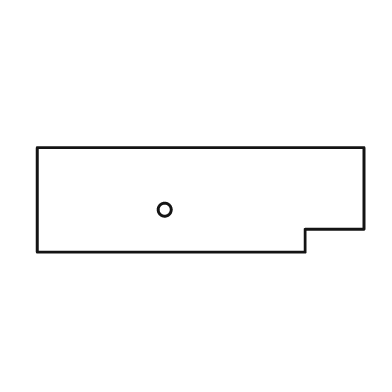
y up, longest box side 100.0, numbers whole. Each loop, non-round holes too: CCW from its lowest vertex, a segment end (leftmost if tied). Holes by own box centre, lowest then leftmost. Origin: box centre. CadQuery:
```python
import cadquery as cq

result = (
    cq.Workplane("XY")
    .moveTo(-50.0, -16.0)
    .lineTo(32.0, -16.0)
    .lineTo(32.0, -9.0)
    .lineTo(50.0, -9.0)
    .lineTo(50.0, 16.0)
    .lineTo(-50.0, 16.0)
    .close()
    .moveTo(-11.0, -3.0)
    .circle(2.0)
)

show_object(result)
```